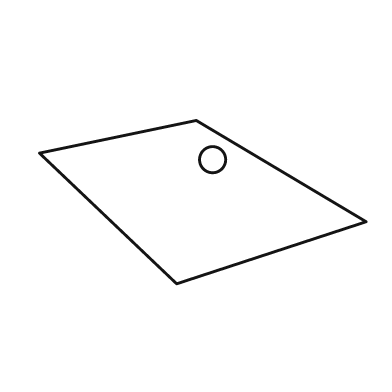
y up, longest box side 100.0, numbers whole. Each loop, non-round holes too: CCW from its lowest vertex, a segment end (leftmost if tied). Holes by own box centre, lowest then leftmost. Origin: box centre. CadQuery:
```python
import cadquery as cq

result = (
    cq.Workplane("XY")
    .moveTo(-8.0, -25.0)
    .lineTo(50.0, -6.0)
    .lineTo(-2.0, 25.0)
    .lineTo(-50.0, 15.0)
    .close()
    .moveTo(3.0, 13.0)
    .circle(4.0)
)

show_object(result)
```